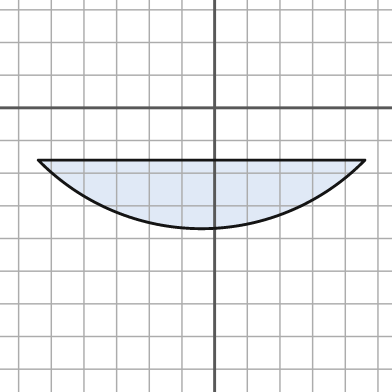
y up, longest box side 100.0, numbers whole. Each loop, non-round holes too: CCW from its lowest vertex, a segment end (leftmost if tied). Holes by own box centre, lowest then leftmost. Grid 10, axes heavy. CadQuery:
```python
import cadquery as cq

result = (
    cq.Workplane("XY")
    .moveTo(-54.0, -16.0)
    .threePointArc((-4.0, -37.0), (46.0, -16.0))
    .close()
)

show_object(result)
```